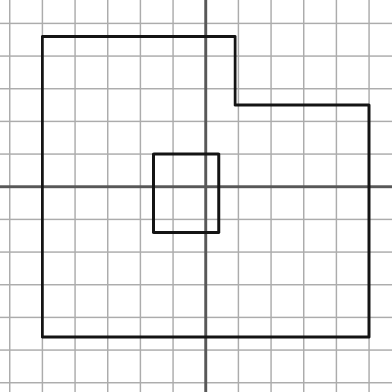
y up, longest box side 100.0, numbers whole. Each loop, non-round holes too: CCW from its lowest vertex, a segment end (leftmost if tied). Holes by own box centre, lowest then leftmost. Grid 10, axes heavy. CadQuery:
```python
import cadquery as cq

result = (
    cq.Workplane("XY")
    .moveTo(-50.0, -46.0)
    .lineTo(50.0, -46.0)
    .lineTo(50.0, 25.0)
    .lineTo(9.0, 25.0)
    .lineTo(9.0, 46.0)
    .lineTo(-50.0, 46.0)
    .close()
    .moveTo(-16.0, -14.0)
    .lineTo(4.0, -14.0)
    .lineTo(4.0, 10.0)
    .lineTo(-16.0, 10.0)
    .close()
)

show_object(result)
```